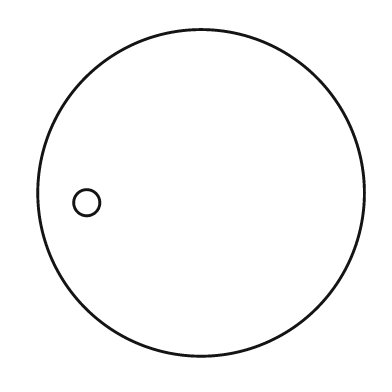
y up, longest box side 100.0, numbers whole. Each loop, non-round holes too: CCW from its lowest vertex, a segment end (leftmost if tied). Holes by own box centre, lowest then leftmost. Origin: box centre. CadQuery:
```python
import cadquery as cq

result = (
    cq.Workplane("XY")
    .moveTo(0.0, 0.0)
    .circle(50.0)
    .moveTo(-35.0, -3.0)
    .circle(4.0)
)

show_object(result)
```